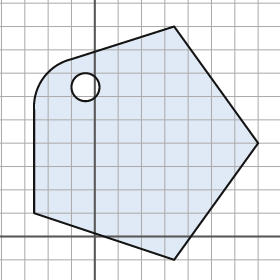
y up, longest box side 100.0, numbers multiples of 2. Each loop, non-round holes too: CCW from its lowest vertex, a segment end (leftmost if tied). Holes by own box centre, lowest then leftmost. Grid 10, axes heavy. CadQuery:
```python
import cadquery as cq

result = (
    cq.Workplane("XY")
    .moveTo(34.0, -10.0)
    .lineTo(70.0, 40.0)
    .lineTo(34.0, 90.0)
    .lineTo(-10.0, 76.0)
    .threePointArc((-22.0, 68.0), (-26.0, 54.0))
    .lineTo(-26.0, 10.0)
    .close()
    .moveTo(-4.0, 64.0)
    .circle(6.0)
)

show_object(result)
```